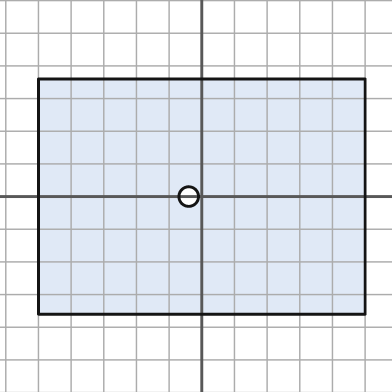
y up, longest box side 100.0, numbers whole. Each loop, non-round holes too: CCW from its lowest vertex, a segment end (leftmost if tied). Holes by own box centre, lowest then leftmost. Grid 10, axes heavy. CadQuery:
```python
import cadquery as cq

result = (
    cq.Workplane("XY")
    .moveTo(-50.0, -36.0)
    .lineTo(50.0, -36.0)
    .lineTo(50.0, 36.0)
    .lineTo(-50.0, 36.0)
    .close()
    .moveTo(-4.0, 0.0)
    .circle(3.0)
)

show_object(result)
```